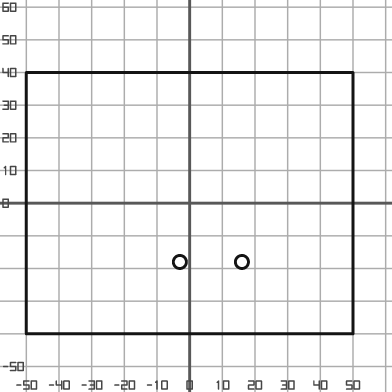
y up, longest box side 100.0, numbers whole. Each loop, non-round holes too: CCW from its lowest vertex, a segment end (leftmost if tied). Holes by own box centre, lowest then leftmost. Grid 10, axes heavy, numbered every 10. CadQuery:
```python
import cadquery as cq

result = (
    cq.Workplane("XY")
    .moveTo(-50.0, -40.0)
    .lineTo(50.0, -40.0)
    .lineTo(50.0, 40.0)
    .lineTo(-50.0, 40.0)
    .close()
    .moveTo(-3.0, -18.0)
    .circle(2.0)
    .moveTo(16.0, -18.0)
    .circle(2.0)
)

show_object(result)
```